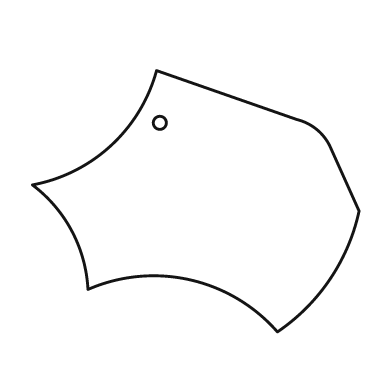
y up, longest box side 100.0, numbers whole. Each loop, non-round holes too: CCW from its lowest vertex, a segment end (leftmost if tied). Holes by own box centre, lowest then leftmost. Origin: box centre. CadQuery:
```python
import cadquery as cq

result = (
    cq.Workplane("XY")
    .moveTo(25.0, -40.0)
    .threePointArc((41.0, -24.0), (50.0, -3.0))
    .lineTo(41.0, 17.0)
    .threePointArc((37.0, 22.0), (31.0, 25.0))
    .lineTo(-12.0, 40.0)
    .threePointArc((-26.0, 17.0), (-50.0, 5.0))
    .threePointArc((-38.0, -9.0), (-33.0, -27.0))
    .threePointArc((-2.0, -24.0), (25.0, -40.0))
    .close()
    .moveTo(-11.0, 24.0)
    .circle(2.0)
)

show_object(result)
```